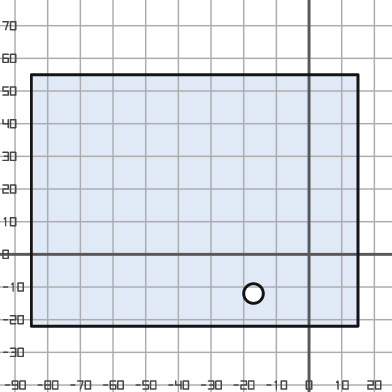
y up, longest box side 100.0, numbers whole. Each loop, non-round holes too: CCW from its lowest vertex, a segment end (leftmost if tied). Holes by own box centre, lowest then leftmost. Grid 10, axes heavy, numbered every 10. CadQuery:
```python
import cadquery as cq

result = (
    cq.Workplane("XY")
    .moveTo(-85.0, -22.0)
    .lineTo(15.0, -22.0)
    .lineTo(15.0, 55.0)
    .lineTo(-85.0, 55.0)
    .close()
    .moveTo(-17.0, -12.0)
    .circle(3.0)
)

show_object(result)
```